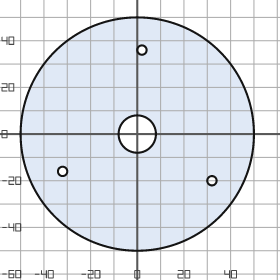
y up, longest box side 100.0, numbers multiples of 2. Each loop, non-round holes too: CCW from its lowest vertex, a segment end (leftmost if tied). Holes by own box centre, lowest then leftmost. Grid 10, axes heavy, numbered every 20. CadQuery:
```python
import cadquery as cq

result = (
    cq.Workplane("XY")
    .moveTo(0.0, 0.0)
    .circle(50.0)
    .moveTo(32.0, -20.0)
    .circle(2.0)
    .moveTo(-32.0, -16.0)
    .circle(2.0)
    .moveTo(0.0, 0.0)
    .circle(8.0)
    .moveTo(2.0, 36.0)
    .circle(2.0)
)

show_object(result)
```